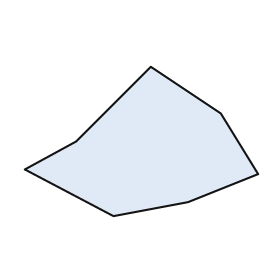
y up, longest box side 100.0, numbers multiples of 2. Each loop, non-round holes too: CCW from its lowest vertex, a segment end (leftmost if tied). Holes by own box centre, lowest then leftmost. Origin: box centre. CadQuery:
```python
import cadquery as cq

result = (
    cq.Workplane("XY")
    .moveTo(-12.0, -32.0)
    .lineTo(20.0, -26.0)
    .lineTo(50.0, -14.0)
    .lineTo(34.0, 12.0)
    .lineTo(4.0, 32.0)
    .lineTo(-28.0, 0.0)
    .lineTo(-50.0, -12.0)
    .close()
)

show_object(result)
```